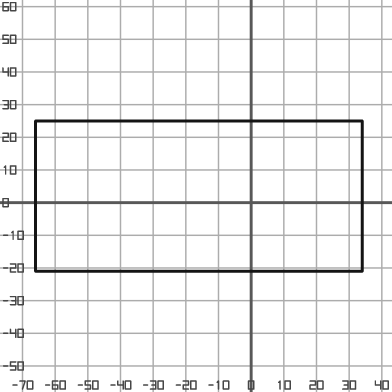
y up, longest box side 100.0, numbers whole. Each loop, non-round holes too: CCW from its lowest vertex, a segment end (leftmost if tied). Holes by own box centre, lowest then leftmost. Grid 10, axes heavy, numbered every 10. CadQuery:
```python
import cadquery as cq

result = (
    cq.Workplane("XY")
    .moveTo(-66.0, -21.0)
    .lineTo(34.0, -21.0)
    .lineTo(34.0, 25.0)
    .lineTo(-66.0, 25.0)
    .close()
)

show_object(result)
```